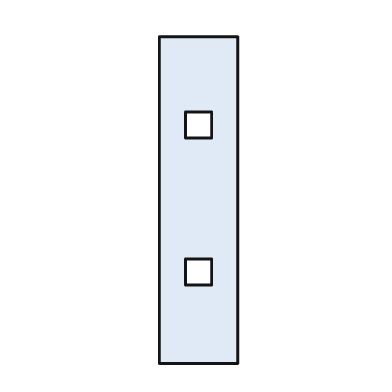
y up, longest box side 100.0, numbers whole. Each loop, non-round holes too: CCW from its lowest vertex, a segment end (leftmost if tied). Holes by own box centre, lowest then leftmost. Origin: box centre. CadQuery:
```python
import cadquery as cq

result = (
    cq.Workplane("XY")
    .moveTo(-12.0, -50.0)
    .lineTo(12.0, -50.0)
    .lineTo(12.0, 50.0)
    .lineTo(-12.0, 50.0)
    .close()
    .moveTo(-4.0, -26.0)
    .lineTo(4.0, -26.0)
    .lineTo(4.0, -18.0)
    .lineTo(-4.0, -18.0)
    .close()
    .moveTo(-4.0, 19.0)
    .lineTo(4.0, 19.0)
    .lineTo(4.0, 27.0)
    .lineTo(-4.0, 27.0)
    .close()
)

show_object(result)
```